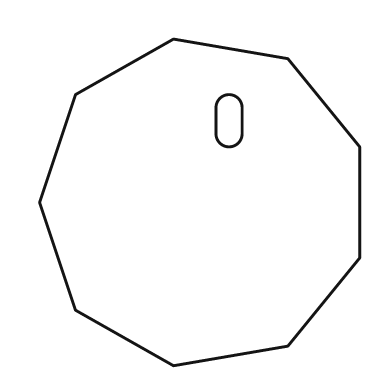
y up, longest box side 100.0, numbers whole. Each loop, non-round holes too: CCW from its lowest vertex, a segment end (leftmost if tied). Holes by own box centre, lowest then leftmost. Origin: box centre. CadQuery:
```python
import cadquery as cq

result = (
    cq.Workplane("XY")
    .moveTo(-8.0, -50.0)
    .lineTo(27.0, -44.0)
    .lineTo(49.0, -17.0)
    .lineTo(49.0, 17.0)
    .lineTo(27.0, 44.0)
    .lineTo(-8.0, 50.0)
    .lineTo(-38.0, 33.0)
    .lineTo(-49.0, 0.0)
    .lineTo(-38.0, -33.0)
    .close()
    .moveTo(5.0, 21.0)
    .threePointArc((9.0, 17.0), (13.0, 21.0))
    .lineTo(13.0, 29.0)
    .threePointArc((9.0, 33.0), (5.0, 29.0))
    .close()
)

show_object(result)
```